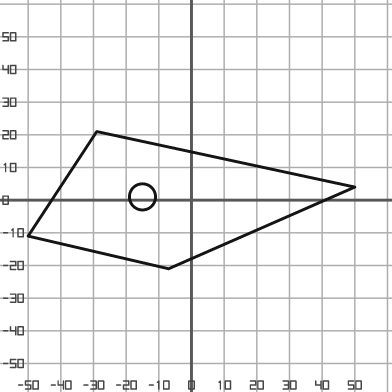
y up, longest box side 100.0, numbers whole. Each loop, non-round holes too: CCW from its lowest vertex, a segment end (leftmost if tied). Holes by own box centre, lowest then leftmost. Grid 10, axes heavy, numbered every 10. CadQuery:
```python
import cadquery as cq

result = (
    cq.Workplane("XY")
    .moveTo(-7.0, -21.0)
    .lineTo(50.0, 4.0)
    .lineTo(-29.0, 21.0)
    .lineTo(-50.0, -11.0)
    .close()
    .moveTo(-15.0, 1.0)
    .circle(4.0)
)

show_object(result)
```